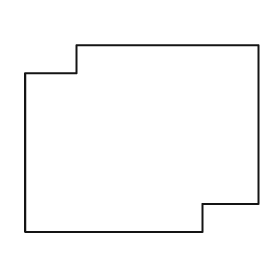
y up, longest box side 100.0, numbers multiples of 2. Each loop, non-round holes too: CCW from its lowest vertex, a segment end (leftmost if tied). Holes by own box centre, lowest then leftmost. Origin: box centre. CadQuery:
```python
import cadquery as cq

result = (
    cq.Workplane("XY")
    .moveTo(-50.0, -40.0)
    .lineTo(26.0, -40.0)
    .lineTo(26.0, -28.0)
    .lineTo(50.0, -28.0)
    .lineTo(50.0, 40.0)
    .lineTo(-28.0, 40.0)
    .lineTo(-28.0, 28.0)
    .lineTo(-50.0, 28.0)
    .close()
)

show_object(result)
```